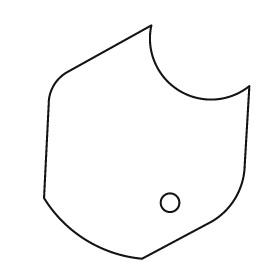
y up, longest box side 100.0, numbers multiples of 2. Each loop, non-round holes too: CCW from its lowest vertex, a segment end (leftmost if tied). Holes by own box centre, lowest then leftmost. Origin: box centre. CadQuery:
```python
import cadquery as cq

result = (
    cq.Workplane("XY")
    .moveTo(-2.0, -50.0)
    .lineTo(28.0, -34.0)
    .threePointArc((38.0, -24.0), (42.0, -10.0))
    .lineTo(44.0, 24.0)
    .threePointArc((14.0, 22.0), (2.0, 50.0))
    .lineTo(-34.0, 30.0)
    .threePointArc((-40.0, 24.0), (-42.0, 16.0))
    .lineTo(-44.0, -24.0)
    .threePointArc((-26.0, -42.0), (-2.0, -50.0))
    .close()
    .moveTo(10.0, -26.0)
    .circle(4.0)
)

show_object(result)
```